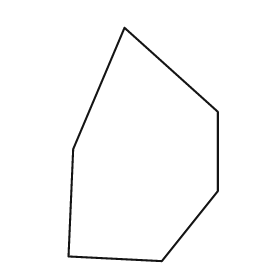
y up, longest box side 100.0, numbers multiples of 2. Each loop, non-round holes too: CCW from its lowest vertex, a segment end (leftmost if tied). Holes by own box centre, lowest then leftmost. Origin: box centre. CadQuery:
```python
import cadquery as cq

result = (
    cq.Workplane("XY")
    .moveTo(8.0, -50.0)
    .lineTo(32.0, -20.0)
    .lineTo(32.0, 14.0)
    .lineTo(-8.0, 50.0)
    .lineTo(-30.0, -2.0)
    .lineTo(-32.0, -48.0)
    .close()
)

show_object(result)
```